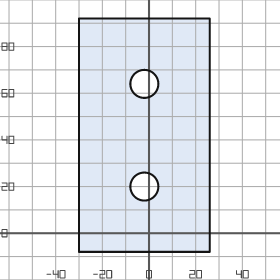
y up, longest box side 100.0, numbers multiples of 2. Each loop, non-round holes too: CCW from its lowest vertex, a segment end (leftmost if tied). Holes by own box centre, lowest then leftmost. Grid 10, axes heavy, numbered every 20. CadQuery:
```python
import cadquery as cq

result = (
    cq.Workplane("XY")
    .moveTo(-30.0, -8.0)
    .lineTo(26.0, -8.0)
    .lineTo(26.0, 92.0)
    .lineTo(-30.0, 92.0)
    .close()
    .moveTo(-2.0, 20.0)
    .circle(6.0)
    .moveTo(-2.0, 64.0)
    .circle(6.0)
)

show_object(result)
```